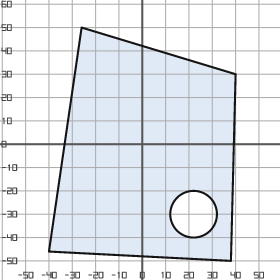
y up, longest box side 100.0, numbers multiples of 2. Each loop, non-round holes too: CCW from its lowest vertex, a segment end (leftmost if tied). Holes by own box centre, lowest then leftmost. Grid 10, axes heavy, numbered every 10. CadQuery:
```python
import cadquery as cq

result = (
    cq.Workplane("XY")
    .moveTo(38.0, -50.0)
    .lineTo(40.0, 30.0)
    .lineTo(-26.0, 50.0)
    .lineTo(-40.0, -46.0)
    .close()
    .moveTo(22.0, -30.0)
    .circle(10.0)
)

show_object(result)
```